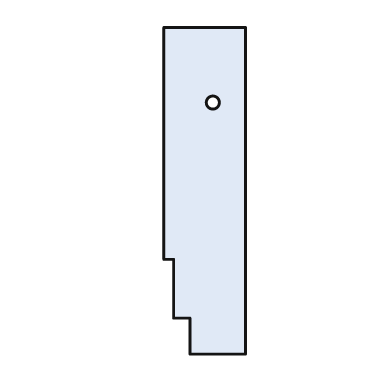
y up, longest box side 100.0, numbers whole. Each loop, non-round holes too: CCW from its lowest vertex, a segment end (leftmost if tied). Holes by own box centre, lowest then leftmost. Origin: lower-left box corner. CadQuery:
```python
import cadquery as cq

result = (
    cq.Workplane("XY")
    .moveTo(8.0, 0.0)
    .lineTo(25.0, 0.0)
    .lineTo(25.0, 100.0)
    .lineTo(0.0, 100.0)
    .lineTo(0.0, 29.0)
    .lineTo(3.0, 29.0)
    .lineTo(3.0, 11.0)
    .lineTo(8.0, 11.0)
    .close()
    .moveTo(15.0, 77.0)
    .circle(2.0)
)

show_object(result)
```